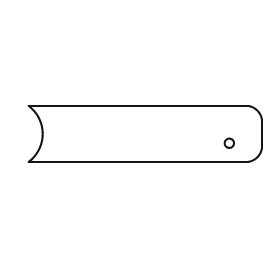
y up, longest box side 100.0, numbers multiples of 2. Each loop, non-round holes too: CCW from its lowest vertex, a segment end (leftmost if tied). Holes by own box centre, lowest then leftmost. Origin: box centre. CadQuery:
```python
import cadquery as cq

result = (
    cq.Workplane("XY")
    .moveTo(-50.0, -12.0)
    .lineTo(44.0, -12.0)
    .threePointArc((48.0, -10.0), (50.0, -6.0))
    .lineTo(50.0, 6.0)
    .threePointArc((48.0, 10.0), (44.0, 12.0))
    .lineTo(-50.0, 12.0)
    .threePointArc((-44.0, 0.0), (-50.0, -12.0))
    .close()
    .moveTo(36.0, -4.0)
    .circle(2.0)
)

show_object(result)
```